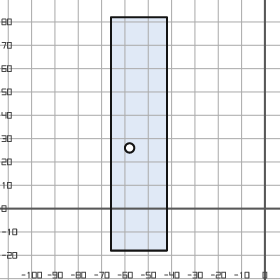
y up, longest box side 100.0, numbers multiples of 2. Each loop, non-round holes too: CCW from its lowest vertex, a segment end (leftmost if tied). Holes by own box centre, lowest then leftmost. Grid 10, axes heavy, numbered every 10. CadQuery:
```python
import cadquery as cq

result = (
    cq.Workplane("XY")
    .moveTo(-66.0, -18.0)
    .lineTo(-42.0, -18.0)
    .lineTo(-42.0, 82.0)
    .lineTo(-66.0, 82.0)
    .close()
    .moveTo(-58.0, 26.0)
    .circle(2.0)
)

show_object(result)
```